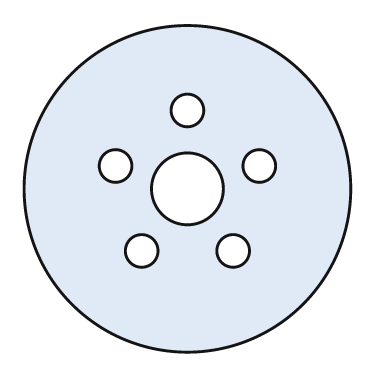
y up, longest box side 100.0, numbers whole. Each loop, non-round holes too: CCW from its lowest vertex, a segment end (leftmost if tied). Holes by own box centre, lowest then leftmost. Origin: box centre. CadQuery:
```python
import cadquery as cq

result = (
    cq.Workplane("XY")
    .moveTo(0.0, 0.0)
    .circle(50.0)
    .moveTo(-14.0, -19.0)
    .circle(5.0)
    .moveTo(14.0, -19.0)
    .circle(5.0)
    .moveTo(0.0, 0.0)
    .circle(11.0)
    .moveTo(-22.0, 7.0)
    .circle(5.0)
    .moveTo(22.0, 7.0)
    .circle(5.0)
    .moveTo(0.0, 24.0)
    .circle(5.0)
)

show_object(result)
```